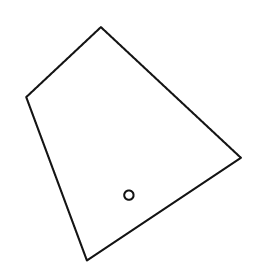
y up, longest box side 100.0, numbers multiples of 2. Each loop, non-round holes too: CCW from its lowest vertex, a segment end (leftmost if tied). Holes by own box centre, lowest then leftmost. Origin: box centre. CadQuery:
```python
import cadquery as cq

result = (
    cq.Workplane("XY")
    .moveTo(-20.0, -50.0)
    .lineTo(46.0, -6.0)
    .lineTo(-14.0, 50.0)
    .lineTo(-46.0, 20.0)
    .close()
    .moveTo(-2.0, -22.0)
    .circle(2.0)
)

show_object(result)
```